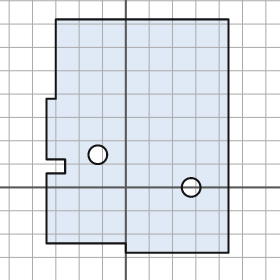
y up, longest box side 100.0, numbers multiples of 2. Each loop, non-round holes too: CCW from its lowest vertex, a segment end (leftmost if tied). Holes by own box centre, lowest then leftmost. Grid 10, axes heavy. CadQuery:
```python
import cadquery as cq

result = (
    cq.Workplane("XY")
    .moveTo(0.0, -28.0)
    .lineTo(44.0, -28.0)
    .lineTo(44.0, 72.0)
    .lineTo(-30.0, 72.0)
    .lineTo(-30.0, 38.0)
    .lineTo(-34.0, 38.0)
    .lineTo(-34.0, 12.0)
    .lineTo(-26.0, 12.0)
    .lineTo(-26.0, 6.0)
    .lineTo(-34.0, 6.0)
    .lineTo(-34.0, -24.0)
    .lineTo(0.0, -24.0)
    .close()
    .moveTo(28.0, 0.0)
    .circle(4.0)
    .moveTo(-12.0, 14.0)
    .circle(4.0)
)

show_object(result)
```